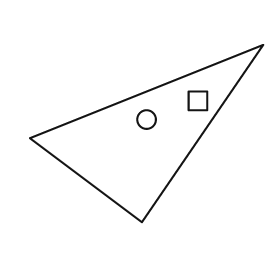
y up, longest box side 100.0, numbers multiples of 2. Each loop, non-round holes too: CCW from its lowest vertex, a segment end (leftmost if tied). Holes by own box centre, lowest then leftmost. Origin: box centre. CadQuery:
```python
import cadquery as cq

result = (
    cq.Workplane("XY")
    .moveTo(-2.0, -38.0)
    .lineTo(50.0, 38.0)
    .lineTo(-50.0, -2.0)
    .close()
    .moveTo(0.0, 6.0)
    .circle(4.0)
    .moveTo(18.0, 10.0)
    .lineTo(26.0, 10.0)
    .lineTo(26.0, 18.0)
    .lineTo(18.0, 18.0)
    .close()
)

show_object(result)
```